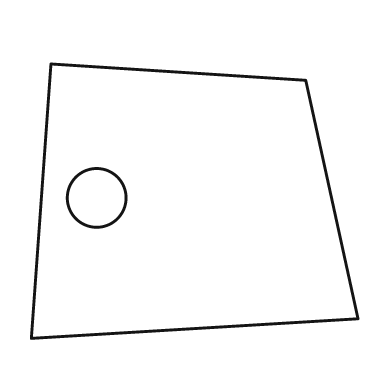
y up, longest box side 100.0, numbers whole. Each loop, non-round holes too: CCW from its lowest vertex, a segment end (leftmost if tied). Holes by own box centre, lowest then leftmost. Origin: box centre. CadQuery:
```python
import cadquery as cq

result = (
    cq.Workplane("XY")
    .moveTo(-50.0, -42.0)
    .lineTo(50.0, -36.0)
    .lineTo(34.0, 37.0)
    .lineTo(-44.0, 42.0)
    .close()
    .moveTo(-30.0, 1.0)
    .circle(9.0)
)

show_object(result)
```